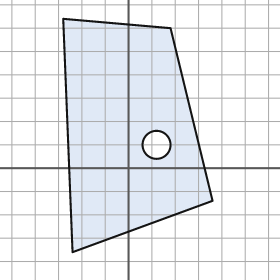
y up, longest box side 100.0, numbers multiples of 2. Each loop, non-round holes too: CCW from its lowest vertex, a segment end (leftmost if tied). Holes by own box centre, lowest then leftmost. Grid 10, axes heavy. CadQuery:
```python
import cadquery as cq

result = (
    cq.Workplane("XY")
    .moveTo(-24.0, -36.0)
    .lineTo(36.0, -14.0)
    .lineTo(18.0, 60.0)
    .lineTo(-28.0, 64.0)
    .close()
    .moveTo(12.0, 10.0)
    .circle(6.0)
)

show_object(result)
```